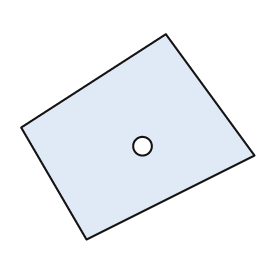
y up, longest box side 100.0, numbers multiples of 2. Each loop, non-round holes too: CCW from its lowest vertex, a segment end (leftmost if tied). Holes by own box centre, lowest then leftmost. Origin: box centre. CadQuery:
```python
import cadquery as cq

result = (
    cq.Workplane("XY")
    .moveTo(-22.0, -44.0)
    .lineTo(50.0, -8.0)
    .lineTo(12.0, 44.0)
    .lineTo(-50.0, 4.0)
    .close()
    .moveTo(2.0, -4.0)
    .circle(4.0)
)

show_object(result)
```